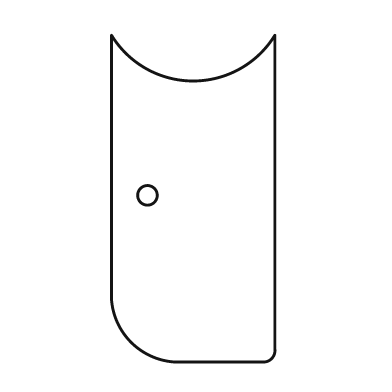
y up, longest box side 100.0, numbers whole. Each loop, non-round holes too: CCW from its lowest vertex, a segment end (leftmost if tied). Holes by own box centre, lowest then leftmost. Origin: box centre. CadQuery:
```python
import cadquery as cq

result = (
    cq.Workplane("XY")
    .moveTo(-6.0, -50.0)
    .lineTo(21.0, -50.0)
    .threePointArc((24.0, -49.0), (25.0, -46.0))
    .lineTo(25.0, 50.0)
    .threePointArc((0.0, 36.0), (-25.0, 50.0))
    .lineTo(-25.0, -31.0)
    .threePointArc((-19.0, -44.0), (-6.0, -50.0))
    .close()
    .moveTo(-14.0, 1.0)
    .circle(3.0)
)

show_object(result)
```